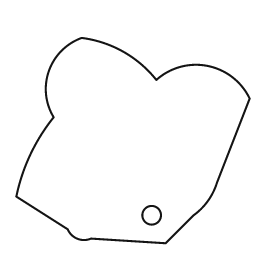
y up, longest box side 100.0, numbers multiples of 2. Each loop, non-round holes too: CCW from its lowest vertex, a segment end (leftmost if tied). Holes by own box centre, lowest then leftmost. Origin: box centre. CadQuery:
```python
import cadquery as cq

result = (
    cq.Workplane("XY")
    .moveTo(14.0, -44.0)
    .lineTo(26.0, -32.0)
    .threePointArc((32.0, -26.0), (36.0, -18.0))
    .lineTo(50.0, 18.0)
    .threePointArc((32.0, 32.0), (10.0, 26.0))
    .threePointArc((-4.0, 38.0), (-22.0, 44.0))
    .threePointArc((-36.0, 30.0), (-34.0, 10.0))
    .threePointArc((-44.0, -6.0), (-50.0, -24.0))
    .lineTo(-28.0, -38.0)
    .threePointArc((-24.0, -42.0), (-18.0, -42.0))
    .close()
    .moveTo(8.0, -32.0)
    .circle(4.0)
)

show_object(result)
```